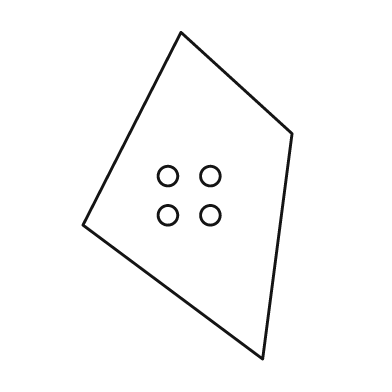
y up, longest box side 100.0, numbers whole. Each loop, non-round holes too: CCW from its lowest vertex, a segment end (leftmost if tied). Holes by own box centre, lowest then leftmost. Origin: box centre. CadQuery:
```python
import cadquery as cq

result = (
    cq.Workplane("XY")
    .moveTo(23.0, -50.0)
    .lineTo(32.0, 19.0)
    .lineTo(-2.0, 50.0)
    .lineTo(-32.0, -9.0)
    .close()
    .moveTo(-6.0, -6.0)
    .circle(3.0)
    .moveTo(7.0, -6.0)
    .circle(3.0)
    .moveTo(-6.0, 6.0)
    .circle(3.0)
    .moveTo(7.0, 6.0)
    .circle(3.0)
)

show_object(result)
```